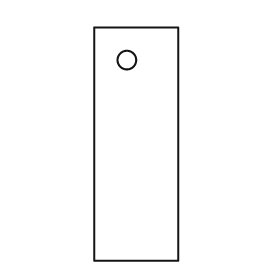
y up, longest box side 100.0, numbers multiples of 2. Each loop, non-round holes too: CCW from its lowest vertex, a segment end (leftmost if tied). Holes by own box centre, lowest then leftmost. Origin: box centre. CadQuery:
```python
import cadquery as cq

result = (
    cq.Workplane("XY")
    .moveTo(-18.0, -50.0)
    .lineTo(18.0, -50.0)
    .lineTo(18.0, 50.0)
    .lineTo(-18.0, 50.0)
    .close()
    .moveTo(-4.0, 36.0)
    .circle(4.0)
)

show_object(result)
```